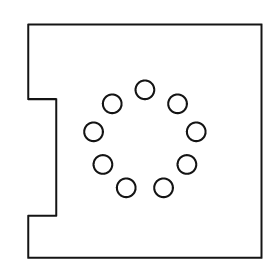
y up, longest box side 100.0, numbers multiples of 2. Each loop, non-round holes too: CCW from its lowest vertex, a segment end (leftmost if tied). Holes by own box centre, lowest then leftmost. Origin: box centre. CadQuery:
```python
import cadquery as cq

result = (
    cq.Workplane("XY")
    .moveTo(-50.0, -50.0)
    .lineTo(50.0, -50.0)
    .lineTo(50.0, 50.0)
    .lineTo(-50.0, 50.0)
    .lineTo(-50.0, 18.0)
    .lineTo(-38.0, 18.0)
    .lineTo(-38.0, -32.0)
    .lineTo(-50.0, -32.0)
    .close()
    .moveTo(-8.0, -20.0)
    .circle(4.0)
    .moveTo(8.0, -20.0)
    .circle(4.0)
    .moveTo(-18.0, -10.0)
    .circle(4.0)
    .moveTo(18.0, -10.0)
    .circle(4.0)
    .moveTo(-22.0, 4.0)
    .circle(4.0)
    .moveTo(22.0, 4.0)
    .circle(4.0)
    .moveTo(-14.0, 16.0)
    .circle(4.0)
    .moveTo(14.0, 16.0)
    .circle(4.0)
    .moveTo(0.0, 22.0)
    .circle(4.0)
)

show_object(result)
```